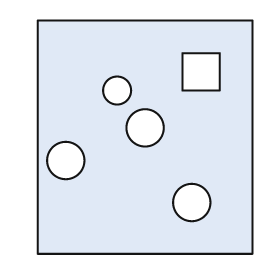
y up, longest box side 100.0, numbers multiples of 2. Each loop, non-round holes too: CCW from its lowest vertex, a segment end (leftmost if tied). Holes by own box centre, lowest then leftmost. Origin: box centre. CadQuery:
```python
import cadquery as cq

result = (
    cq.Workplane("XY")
    .moveTo(-46.0, -50.0)
    .lineTo(46.0, -50.0)
    .lineTo(46.0, 50.0)
    .lineTo(-46.0, 50.0)
    .close()
    .moveTo(20.0, -28.0)
    .circle(8.0)
    .moveTo(-34.0, -10.0)
    .circle(8.0)
    .moveTo(0.0, 4.0)
    .circle(8.0)
    .moveTo(-12.0, 20.0)
    .circle(6.0)
    .moveTo(16.0, 20.0)
    .lineTo(32.0, 20.0)
    .lineTo(32.0, 36.0)
    .lineTo(16.0, 36.0)
    .close()
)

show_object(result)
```